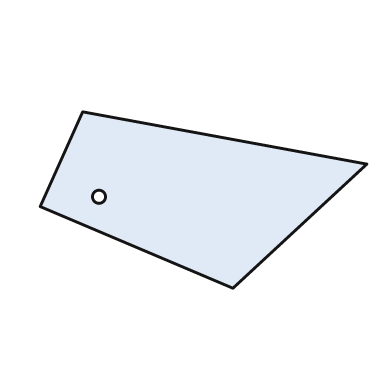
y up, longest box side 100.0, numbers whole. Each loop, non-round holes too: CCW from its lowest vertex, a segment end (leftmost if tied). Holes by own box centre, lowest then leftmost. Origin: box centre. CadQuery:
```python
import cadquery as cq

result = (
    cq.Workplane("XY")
    .moveTo(9.0, -27.0)
    .lineTo(50.0, 11.0)
    .lineTo(-37.0, 27.0)
    .lineTo(-50.0, -2.0)
    .close()
    .moveTo(-32.0, 1.0)
    .circle(2.0)
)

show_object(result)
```